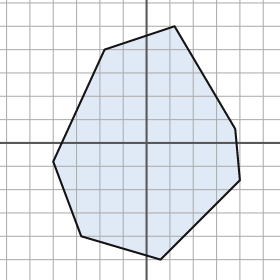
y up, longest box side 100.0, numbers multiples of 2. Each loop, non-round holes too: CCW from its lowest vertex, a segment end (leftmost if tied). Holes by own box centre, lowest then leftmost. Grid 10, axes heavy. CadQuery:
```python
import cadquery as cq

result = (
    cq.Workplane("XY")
    .moveTo(6.0, -50.0)
    .lineTo(40.0, -16.0)
    .lineTo(38.0, 6.0)
    .lineTo(12.0, 50.0)
    .lineTo(-18.0, 40.0)
    .lineTo(-40.0, -8.0)
    .lineTo(-28.0, -40.0)
    .close()
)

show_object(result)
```